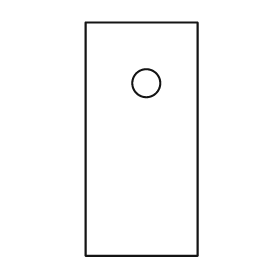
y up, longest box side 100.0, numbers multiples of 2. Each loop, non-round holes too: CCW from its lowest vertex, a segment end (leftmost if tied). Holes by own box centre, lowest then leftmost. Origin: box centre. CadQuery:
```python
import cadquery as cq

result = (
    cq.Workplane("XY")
    .moveTo(-24.0, -50.0)
    .lineTo(24.0, -50.0)
    .lineTo(24.0, 50.0)
    .lineTo(-24.0, 50.0)
    .close()
    .moveTo(2.0, 24.0)
    .circle(6.0)
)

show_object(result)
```